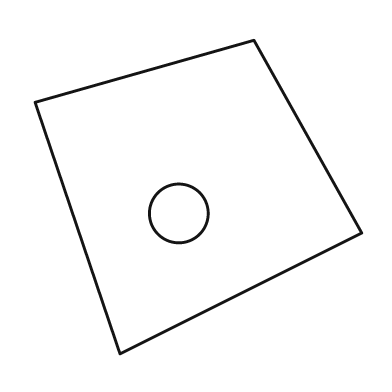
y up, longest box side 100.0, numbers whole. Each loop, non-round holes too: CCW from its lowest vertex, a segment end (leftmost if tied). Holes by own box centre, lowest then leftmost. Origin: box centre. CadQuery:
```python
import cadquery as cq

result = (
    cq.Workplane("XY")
    .moveTo(-24.0, -48.0)
    .lineTo(50.0, -11.0)
    .lineTo(17.0, 48.0)
    .lineTo(-50.0, 29.0)
    .close()
    .moveTo(-6.0, -5.0)
    .circle(9.0)
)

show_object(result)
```